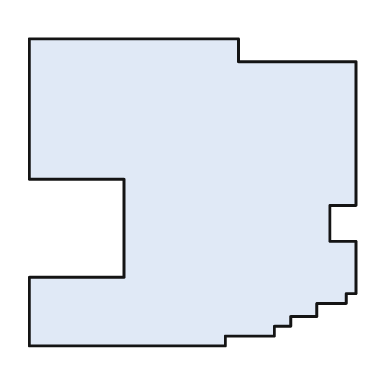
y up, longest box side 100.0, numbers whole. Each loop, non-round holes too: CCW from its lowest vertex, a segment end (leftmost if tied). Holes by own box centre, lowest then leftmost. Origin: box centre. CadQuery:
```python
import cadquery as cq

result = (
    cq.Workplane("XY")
    .moveTo(-50.0, -47.0)
    .lineTo(10.0, -47.0)
    .lineTo(10.0, -44.0)
    .lineTo(25.0, -44.0)
    .lineTo(25.0, -41.0)
    .lineTo(30.0, -41.0)
    .lineTo(30.0, -38.0)
    .lineTo(38.0, -38.0)
    .lineTo(38.0, -34.0)
    .lineTo(47.0, -34.0)
    .lineTo(47.0, -31.0)
    .lineTo(50.0, -31.0)
    .lineTo(50.0, -15.0)
    .lineTo(42.0, -15.0)
    .lineTo(42.0, -4.0)
    .lineTo(50.0, -4.0)
    .lineTo(50.0, 40.0)
    .lineTo(14.0, 40.0)
    .lineTo(14.0, 47.0)
    .lineTo(-50.0, 47.0)
    .lineTo(-50.0, 4.0)
    .lineTo(-21.0, 4.0)
    .lineTo(-21.0, -26.0)
    .lineTo(-50.0, -26.0)
    .close()
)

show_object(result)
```